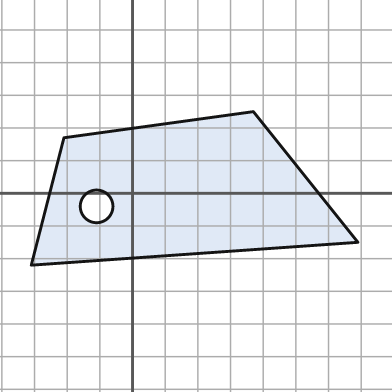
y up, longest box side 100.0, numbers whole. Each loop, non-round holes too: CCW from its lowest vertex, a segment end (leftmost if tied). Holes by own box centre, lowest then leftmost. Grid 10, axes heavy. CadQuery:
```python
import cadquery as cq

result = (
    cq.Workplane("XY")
    .moveTo(-31.0, -22.0)
    .lineTo(69.0, -15.0)
    .lineTo(37.0, 25.0)
    .lineTo(-21.0, 17.0)
    .close()
    .moveTo(-11.0, -4.0)
    .circle(5.0)
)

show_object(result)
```